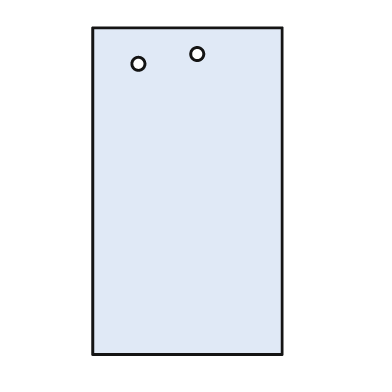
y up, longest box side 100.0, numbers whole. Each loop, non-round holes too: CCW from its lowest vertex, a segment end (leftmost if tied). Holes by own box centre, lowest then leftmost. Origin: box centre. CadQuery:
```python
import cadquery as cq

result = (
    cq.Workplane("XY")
    .moveTo(-29.0, -50.0)
    .lineTo(29.0, -50.0)
    .lineTo(29.0, 50.0)
    .lineTo(-29.0, 50.0)
    .close()
    .moveTo(-15.0, 39.0)
    .circle(2.0)
    .moveTo(3.0, 42.0)
    .circle(2.0)
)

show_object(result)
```